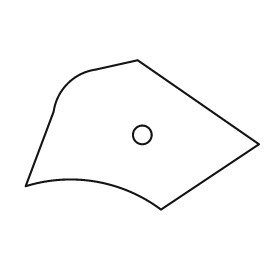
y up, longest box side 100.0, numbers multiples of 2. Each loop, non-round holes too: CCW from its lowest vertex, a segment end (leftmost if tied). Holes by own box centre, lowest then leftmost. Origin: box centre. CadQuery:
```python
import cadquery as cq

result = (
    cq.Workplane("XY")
    .moveTo(8.0, -32.0)
    .lineTo(50.0, -4.0)
    .lineTo(-2.0, 32.0)
    .lineTo(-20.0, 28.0)
    .threePointArc((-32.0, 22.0), (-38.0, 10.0))
    .lineTo(-50.0, -22.0)
    .threePointArc((-20.0, -20.0), (8.0, -32.0))
    .close()
    .moveTo(0.0, 0.0)
    .circle(4.0)
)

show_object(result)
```